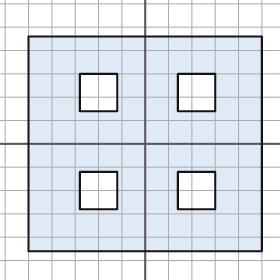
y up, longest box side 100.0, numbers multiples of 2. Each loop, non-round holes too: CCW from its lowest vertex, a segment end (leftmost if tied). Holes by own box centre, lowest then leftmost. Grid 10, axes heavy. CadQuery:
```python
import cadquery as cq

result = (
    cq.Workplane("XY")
    .moveTo(-50.0, -46.0)
    .lineTo(50.0, -46.0)
    .lineTo(50.0, 46.0)
    .lineTo(-50.0, 46.0)
    .close()
    .moveTo(-28.0, -28.0)
    .lineTo(-12.0, -28.0)
    .lineTo(-12.0, -12.0)
    .lineTo(-28.0, -12.0)
    .close()
    .moveTo(14.0, -28.0)
    .lineTo(30.0, -28.0)
    .lineTo(30.0, -12.0)
    .lineTo(14.0, -12.0)
    .close()
    .moveTo(-28.0, 14.0)
    .lineTo(-12.0, 14.0)
    .lineTo(-12.0, 30.0)
    .lineTo(-28.0, 30.0)
    .close()
    .moveTo(14.0, 14.0)
    .lineTo(30.0, 14.0)
    .lineTo(30.0, 30.0)
    .lineTo(14.0, 30.0)
    .close()
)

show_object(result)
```